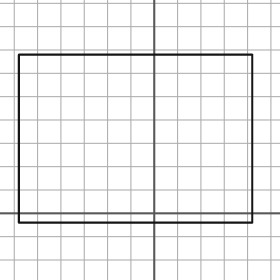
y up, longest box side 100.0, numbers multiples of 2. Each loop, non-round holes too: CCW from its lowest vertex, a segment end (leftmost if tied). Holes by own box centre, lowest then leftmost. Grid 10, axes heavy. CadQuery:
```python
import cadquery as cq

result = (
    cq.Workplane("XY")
    .moveTo(-58.0, -4.0)
    .lineTo(42.0, -4.0)
    .lineTo(42.0, 68.0)
    .lineTo(-58.0, 68.0)
    .close()
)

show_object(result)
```